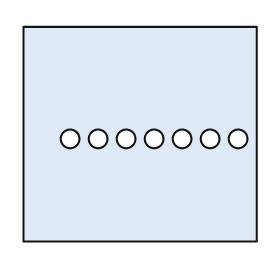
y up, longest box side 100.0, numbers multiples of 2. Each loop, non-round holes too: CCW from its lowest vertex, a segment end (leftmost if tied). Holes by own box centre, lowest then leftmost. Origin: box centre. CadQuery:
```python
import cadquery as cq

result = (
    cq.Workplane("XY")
    .moveTo(-50.0, -46.0)
    .lineTo(50.0, -46.0)
    .lineTo(50.0, 46.0)
    .lineTo(-50.0, 46.0)
    .close()
    .moveTo(-30.0, -2.0)
    .circle(4.0)
    .moveTo(-18.0, -2.0)
    .circle(4.0)
    .moveTo(-6.0, -2.0)
    .circle(4.0)
    .moveTo(6.0, -2.0)
    .circle(4.0)
    .moveTo(18.0, -2.0)
    .circle(4.0)
    .moveTo(30.0, -2.0)
    .circle(4.0)
    .moveTo(42.0, -2.0)
    .circle(4.0)
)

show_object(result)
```